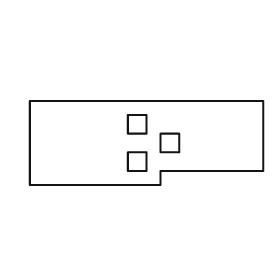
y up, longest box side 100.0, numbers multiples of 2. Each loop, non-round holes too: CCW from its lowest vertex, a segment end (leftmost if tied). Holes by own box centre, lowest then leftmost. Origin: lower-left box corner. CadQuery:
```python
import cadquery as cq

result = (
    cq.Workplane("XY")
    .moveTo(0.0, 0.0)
    .lineTo(56.0, 0.0)
    .lineTo(56.0, 6.0)
    .lineTo(100.0, 6.0)
    .lineTo(100.0, 36.0)
    .lineTo(0.0, 36.0)
    .close()
    .moveTo(42.0, 6.0)
    .lineTo(50.0, 6.0)
    .lineTo(50.0, 14.0)
    .lineTo(42.0, 14.0)
    .close()
    .moveTo(56.0, 14.0)
    .lineTo(64.0, 14.0)
    .lineTo(64.0, 22.0)
    .lineTo(56.0, 22.0)
    .close()
    .moveTo(42.0, 22.0)
    .lineTo(50.0, 22.0)
    .lineTo(50.0, 30.0)
    .lineTo(42.0, 30.0)
    .close()
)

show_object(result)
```